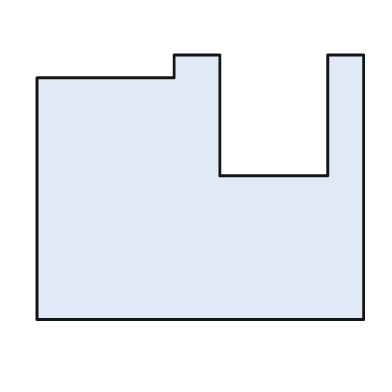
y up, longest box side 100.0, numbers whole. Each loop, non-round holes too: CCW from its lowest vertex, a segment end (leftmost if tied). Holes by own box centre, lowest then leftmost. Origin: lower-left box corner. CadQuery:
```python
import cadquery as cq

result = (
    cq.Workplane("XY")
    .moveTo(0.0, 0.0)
    .lineTo(100.0, 0.0)
    .lineTo(100.0, 81.0)
    .lineTo(89.0, 81.0)
    .lineTo(89.0, 44.0)
    .lineTo(56.0, 44.0)
    .lineTo(56.0, 81.0)
    .lineTo(42.0, 81.0)
    .lineTo(42.0, 74.0)
    .lineTo(0.0, 74.0)
    .close()
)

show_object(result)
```